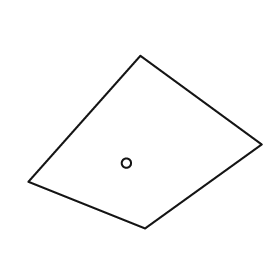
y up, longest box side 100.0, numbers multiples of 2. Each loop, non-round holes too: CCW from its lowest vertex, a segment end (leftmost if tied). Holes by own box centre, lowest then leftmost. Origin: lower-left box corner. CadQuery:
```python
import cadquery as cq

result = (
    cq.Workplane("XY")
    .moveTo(50.0, 0.0)
    .lineTo(100.0, 36.0)
    .lineTo(48.0, 74.0)
    .lineTo(0.0, 20.0)
    .close()
    .moveTo(42.0, 28.0)
    .circle(2.0)
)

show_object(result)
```